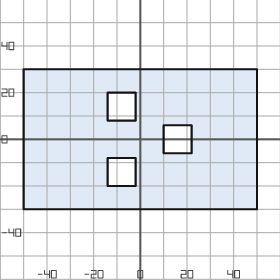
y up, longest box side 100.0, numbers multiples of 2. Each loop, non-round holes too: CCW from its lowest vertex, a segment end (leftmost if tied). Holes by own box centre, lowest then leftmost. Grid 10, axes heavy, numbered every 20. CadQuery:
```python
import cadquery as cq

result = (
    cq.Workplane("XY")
    .moveTo(-50.0, -30.0)
    .lineTo(50.0, -30.0)
    .lineTo(50.0, 30.0)
    .lineTo(-50.0, 30.0)
    .close()
    .moveTo(-14.0, -20.0)
    .lineTo(-2.0, -20.0)
    .lineTo(-2.0, -8.0)
    .lineTo(-14.0, -8.0)
    .close()
    .moveTo(10.0, -6.0)
    .lineTo(22.0, -6.0)
    .lineTo(22.0, 6.0)
    .lineTo(10.0, 6.0)
    .close()
    .moveTo(-14.0, 8.0)
    .lineTo(-2.0, 8.0)
    .lineTo(-2.0, 20.0)
    .lineTo(-14.0, 20.0)
    .close()
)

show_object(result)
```